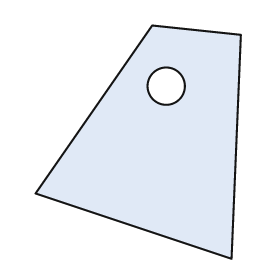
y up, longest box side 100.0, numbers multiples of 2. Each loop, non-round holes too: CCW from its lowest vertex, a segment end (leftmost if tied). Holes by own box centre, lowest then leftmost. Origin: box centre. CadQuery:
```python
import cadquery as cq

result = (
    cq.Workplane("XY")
    .moveTo(40.0, -50.0)
    .lineTo(44.0, 46.0)
    .lineTo(6.0, 50.0)
    .lineTo(-44.0, -22.0)
    .close()
    .moveTo(12.0, 24.0)
    .circle(8.0)
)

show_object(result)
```